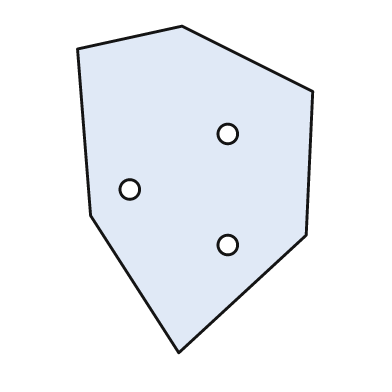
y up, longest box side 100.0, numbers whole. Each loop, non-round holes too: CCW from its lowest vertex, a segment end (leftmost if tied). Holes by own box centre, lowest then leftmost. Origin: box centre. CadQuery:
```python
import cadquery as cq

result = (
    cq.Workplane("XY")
    .moveTo(-5.0, -50.0)
    .lineTo(34.0, -14.0)
    .lineTo(36.0, 30.0)
    .lineTo(-4.0, 50.0)
    .lineTo(-36.0, 43.0)
    .lineTo(-32.0, -8.0)
    .close()
    .moveTo(10.0, -17.0)
    .circle(3.0)
    .moveTo(-20.0, 0.0)
    .circle(3.0)
    .moveTo(10.0, 17.0)
    .circle(3.0)
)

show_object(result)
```